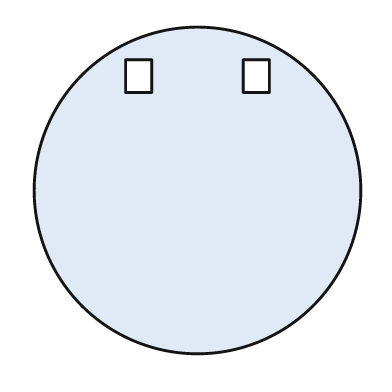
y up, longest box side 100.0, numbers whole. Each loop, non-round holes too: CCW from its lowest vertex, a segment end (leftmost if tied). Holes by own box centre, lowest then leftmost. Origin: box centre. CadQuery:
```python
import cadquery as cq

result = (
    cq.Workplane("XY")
    .moveTo(0.0, 0.0)
    .circle(50.0)
    .moveTo(-22.0, 30.0)
    .lineTo(-14.0, 30.0)
    .lineTo(-14.0, 40.0)
    .lineTo(-22.0, 40.0)
    .close()
    .moveTo(14.0, 30.0)
    .lineTo(22.0, 30.0)
    .lineTo(22.0, 40.0)
    .lineTo(14.0, 40.0)
    .close()
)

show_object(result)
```